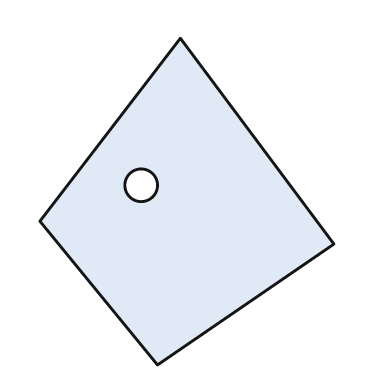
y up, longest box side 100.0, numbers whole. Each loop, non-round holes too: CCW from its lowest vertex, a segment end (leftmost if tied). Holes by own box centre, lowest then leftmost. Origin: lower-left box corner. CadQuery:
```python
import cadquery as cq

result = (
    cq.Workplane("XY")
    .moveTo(36.0, 0.0)
    .lineTo(90.0, 37.0)
    .lineTo(43.0, 100.0)
    .lineTo(0.0, 44.0)
    .close()
    .moveTo(31.0, 55.0)
    .circle(5.0)
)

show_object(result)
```